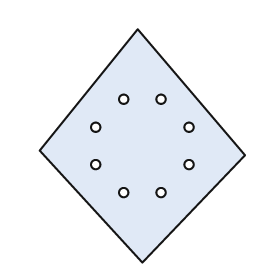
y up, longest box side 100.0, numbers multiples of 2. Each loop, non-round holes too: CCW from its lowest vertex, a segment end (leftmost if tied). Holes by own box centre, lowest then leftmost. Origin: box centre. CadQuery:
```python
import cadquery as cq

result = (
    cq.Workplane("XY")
    .moveTo(0.0, -50.0)
    .lineTo(44.0, -4.0)
    .lineTo(-2.0, 50.0)
    .lineTo(-44.0, -2.0)
    .close()
    .moveTo(-8.0, -20.0)
    .circle(2.0)
    .moveTo(8.0, -20.0)
    .circle(2.0)
    .moveTo(-20.0, -8.0)
    .circle(2.0)
    .moveTo(20.0, -8.0)
    .circle(2.0)
    .moveTo(-20.0, 8.0)
    .circle(2.0)
    .moveTo(20.0, 8.0)
    .circle(2.0)
    .moveTo(-8.0, 20.0)
    .circle(2.0)
    .moveTo(8.0, 20.0)
    .circle(2.0)
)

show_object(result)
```